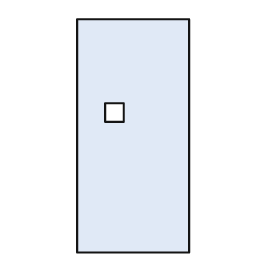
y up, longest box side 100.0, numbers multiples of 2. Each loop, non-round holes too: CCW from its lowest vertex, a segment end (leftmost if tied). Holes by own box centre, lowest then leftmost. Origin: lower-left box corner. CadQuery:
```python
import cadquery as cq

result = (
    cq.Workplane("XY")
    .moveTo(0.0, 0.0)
    .lineTo(48.0, 0.0)
    .lineTo(48.0, 100.0)
    .lineTo(0.0, 100.0)
    .close()
    .moveTo(12.0, 56.0)
    .lineTo(20.0, 56.0)
    .lineTo(20.0, 64.0)
    .lineTo(12.0, 64.0)
    .close()
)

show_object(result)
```